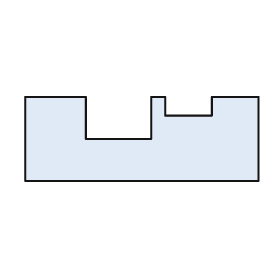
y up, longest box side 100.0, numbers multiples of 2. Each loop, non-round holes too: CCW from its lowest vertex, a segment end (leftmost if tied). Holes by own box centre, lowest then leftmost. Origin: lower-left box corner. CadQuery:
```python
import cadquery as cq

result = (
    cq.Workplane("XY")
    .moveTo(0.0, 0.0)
    .lineTo(100.0, 0.0)
    .lineTo(100.0, 36.0)
    .lineTo(80.0, 36.0)
    .lineTo(80.0, 28.0)
    .lineTo(60.0, 28.0)
    .lineTo(60.0, 36.0)
    .lineTo(54.0, 36.0)
    .lineTo(54.0, 18.0)
    .lineTo(26.0, 18.0)
    .lineTo(26.0, 36.0)
    .lineTo(0.0, 36.0)
    .close()
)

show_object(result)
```